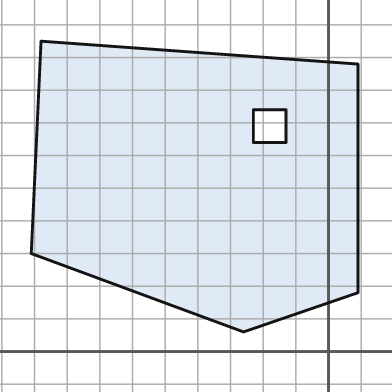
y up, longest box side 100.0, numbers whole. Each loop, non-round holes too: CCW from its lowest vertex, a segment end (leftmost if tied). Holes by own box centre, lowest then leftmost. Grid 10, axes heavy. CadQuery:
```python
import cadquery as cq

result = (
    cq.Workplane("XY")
    .moveTo(-26.0, 6.0)
    .lineTo(9.0, 18.0)
    .lineTo(9.0, 88.0)
    .lineTo(-88.0, 95.0)
    .lineTo(-91.0, 30.0)
    .close()
    .moveTo(-23.0, 64.0)
    .lineTo(-13.0, 64.0)
    .lineTo(-13.0, 74.0)
    .lineTo(-23.0, 74.0)
    .close()
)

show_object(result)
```